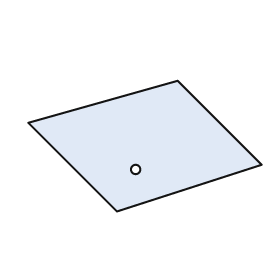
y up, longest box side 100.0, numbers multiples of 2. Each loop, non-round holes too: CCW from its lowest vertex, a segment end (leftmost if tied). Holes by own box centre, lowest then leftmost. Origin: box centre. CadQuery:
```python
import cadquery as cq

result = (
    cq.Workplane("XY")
    .moveTo(-12.0, -28.0)
    .lineTo(50.0, -8.0)
    .lineTo(14.0, 28.0)
    .lineTo(-50.0, 10.0)
    .close()
    .moveTo(-4.0, -10.0)
    .circle(2.0)
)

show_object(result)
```